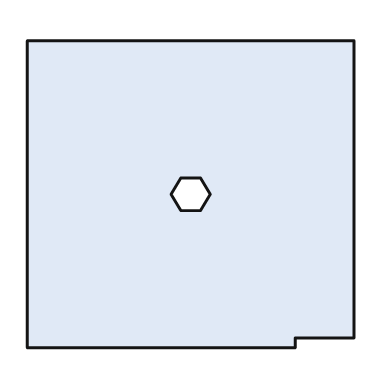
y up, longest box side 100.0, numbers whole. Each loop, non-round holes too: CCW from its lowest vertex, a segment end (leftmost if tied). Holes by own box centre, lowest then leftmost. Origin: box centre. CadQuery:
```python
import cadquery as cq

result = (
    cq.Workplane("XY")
    .moveTo(-50.0, -47.0)
    .lineTo(32.0, -47.0)
    .lineTo(32.0, -44.0)
    .lineTo(50.0, -44.0)
    .lineTo(50.0, 47.0)
    .lineTo(-50.0, 47.0)
    .close()
    .moveTo(-3.0, -5.0)
    .lineTo(3.0, -5.0)
    .lineTo(6.0, 0.0)
    .lineTo(3.0, 5.0)
    .lineTo(-3.0, 5.0)
    .lineTo(-6.0, 0.0)
    .close()
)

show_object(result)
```